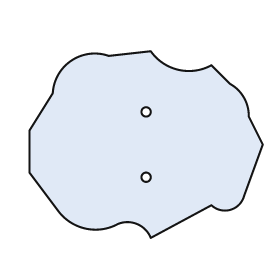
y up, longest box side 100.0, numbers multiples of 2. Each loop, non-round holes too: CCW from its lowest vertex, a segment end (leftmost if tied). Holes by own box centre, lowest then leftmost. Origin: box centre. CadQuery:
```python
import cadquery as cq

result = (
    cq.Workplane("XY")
    .moveTo(2.0, -40.0)
    .lineTo(28.0, -26.0)
    .threePointArc((36.0, -28.0), (42.0, -22.0))
    .lineTo(50.0, 0.0)
    .lineTo(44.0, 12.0)
    .threePointArc((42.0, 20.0), (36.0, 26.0))
    .lineTo(28.0, 34.0)
    .threePointArc((14.0, 32.0), (2.0, 40.0))
    .lineTo(-16.0, 38.0)
    .threePointArc((-32.0, 36.0), (-40.0, 22.0))
    .lineTo(-50.0, 6.0)
    .lineTo(-50.0, -12.0)
    .lineTo(-38.0, -28.0)
    .threePointArc((-26.0, -36.0), (-12.0, -34.0))
    .threePointArc((-4.0, -34.0), (2.0, -40.0))
    .close()
    .moveTo(0.0, -14.0)
    .circle(2.0)
    .moveTo(0.0, 14.0)
    .circle(2.0)
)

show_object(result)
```